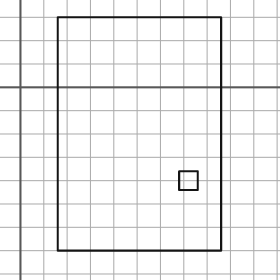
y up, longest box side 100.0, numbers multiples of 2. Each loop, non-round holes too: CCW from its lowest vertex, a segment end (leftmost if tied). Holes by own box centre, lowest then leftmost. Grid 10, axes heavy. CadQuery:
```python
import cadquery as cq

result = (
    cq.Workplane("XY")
    .moveTo(16.0, -70.0)
    .lineTo(86.0, -70.0)
    .lineTo(86.0, 30.0)
    .lineTo(16.0, 30.0)
    .close()
    .moveTo(68.0, -44.0)
    .lineTo(76.0, -44.0)
    .lineTo(76.0, -36.0)
    .lineTo(68.0, -36.0)
    .close()
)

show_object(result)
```